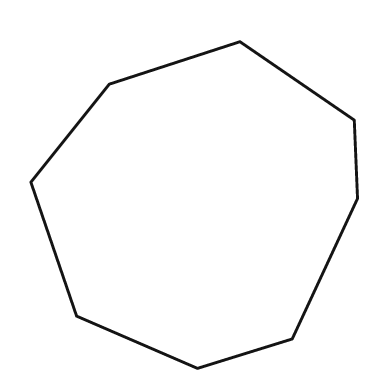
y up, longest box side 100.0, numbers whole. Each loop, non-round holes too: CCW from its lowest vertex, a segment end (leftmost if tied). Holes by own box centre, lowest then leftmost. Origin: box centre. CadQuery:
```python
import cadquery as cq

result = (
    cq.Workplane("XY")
    .moveTo(1.0, -50.0)
    .lineTo(30.0, -41.0)
    .lineTo(50.0, 2.0)
    .lineTo(49.0, 26.0)
    .lineTo(14.0, 50.0)
    .lineTo(-26.0, 37.0)
    .lineTo(-50.0, 7.0)
    .lineTo(-36.0, -34.0)
    .close()
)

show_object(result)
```